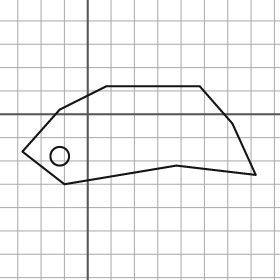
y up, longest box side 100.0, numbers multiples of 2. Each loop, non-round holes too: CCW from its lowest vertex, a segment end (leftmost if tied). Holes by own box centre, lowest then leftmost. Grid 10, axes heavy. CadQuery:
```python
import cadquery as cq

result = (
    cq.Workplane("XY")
    .moveTo(-10.0, -30.0)
    .lineTo(38.0, -22.0)
    .lineTo(72.0, -26.0)
    .lineTo(62.0, -4.0)
    .lineTo(48.0, 12.0)
    .lineTo(8.0, 12.0)
    .lineTo(-12.0, 2.0)
    .lineTo(-28.0, -16.0)
    .close()
    .moveTo(-12.0, -18.0)
    .circle(4.0)
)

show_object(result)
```